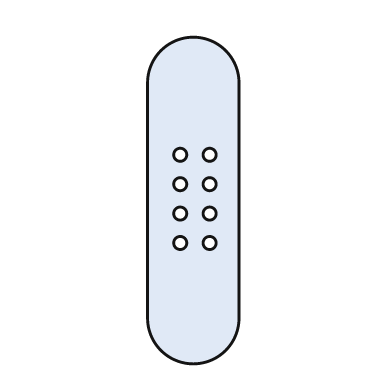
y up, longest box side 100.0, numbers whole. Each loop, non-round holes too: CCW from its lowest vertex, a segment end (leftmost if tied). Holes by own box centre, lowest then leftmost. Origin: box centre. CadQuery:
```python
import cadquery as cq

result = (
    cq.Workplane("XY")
    .moveTo(-14.0, -36.0)
    .threePointArc((0.0, -50.0), (14.0, -36.0))
    .lineTo(14.0, 36.0)
    .threePointArc((0.0, 50.0), (-14.0, 36.0))
    .close()
    .moveTo(-4.0, -13.0)
    .circle(2.0)
    .moveTo(5.0, -13.0)
    .circle(2.0)
    .moveTo(-4.0, -4.0)
    .circle(2.0)
    .moveTo(5.0, -4.0)
    .circle(2.0)
    .moveTo(-4.0, 5.0)
    .circle(2.0)
    .moveTo(5.0, 5.0)
    .circle(2.0)
    .moveTo(-4.0, 14.0)
    .circle(2.0)
    .moveTo(5.0, 14.0)
    .circle(2.0)
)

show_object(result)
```